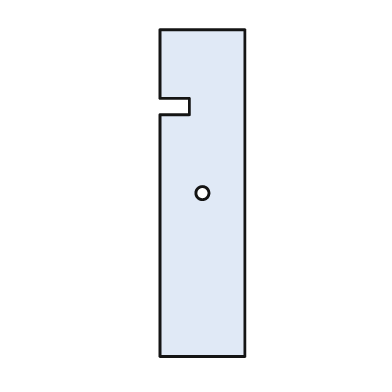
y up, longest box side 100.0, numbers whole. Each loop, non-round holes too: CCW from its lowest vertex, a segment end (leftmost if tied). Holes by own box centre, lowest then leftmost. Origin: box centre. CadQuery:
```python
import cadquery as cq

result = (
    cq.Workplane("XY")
    .moveTo(-13.0, -50.0)
    .lineTo(13.0, -50.0)
    .lineTo(13.0, 50.0)
    .lineTo(-13.0, 50.0)
    .lineTo(-13.0, 29.0)
    .lineTo(-4.0, 29.0)
    .lineTo(-4.0, 24.0)
    .lineTo(-13.0, 24.0)
    .close()
    .moveTo(0.0, 0.0)
    .circle(2.0)
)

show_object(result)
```